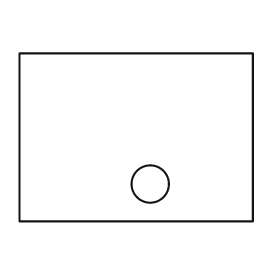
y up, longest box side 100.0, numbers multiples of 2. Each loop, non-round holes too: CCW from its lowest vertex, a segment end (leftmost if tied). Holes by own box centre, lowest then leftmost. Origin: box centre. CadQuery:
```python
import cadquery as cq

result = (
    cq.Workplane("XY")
    .moveTo(-50.0, -36.0)
    .lineTo(50.0, -36.0)
    .lineTo(50.0, 36.0)
    .lineTo(-50.0, 36.0)
    .close()
    .moveTo(6.0, -20.0)
    .circle(8.0)
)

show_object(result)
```